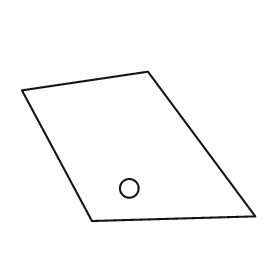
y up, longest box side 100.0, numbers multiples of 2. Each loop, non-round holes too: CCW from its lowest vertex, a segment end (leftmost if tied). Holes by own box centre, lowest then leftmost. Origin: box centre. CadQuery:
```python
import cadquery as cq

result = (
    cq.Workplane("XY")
    .moveTo(-20.0, -32.0)
    .lineTo(50.0, -30.0)
    .lineTo(4.0, 32.0)
    .lineTo(-50.0, 24.0)
    .close()
    .moveTo(-4.0, -18.0)
    .circle(4.0)
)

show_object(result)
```